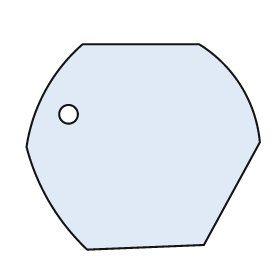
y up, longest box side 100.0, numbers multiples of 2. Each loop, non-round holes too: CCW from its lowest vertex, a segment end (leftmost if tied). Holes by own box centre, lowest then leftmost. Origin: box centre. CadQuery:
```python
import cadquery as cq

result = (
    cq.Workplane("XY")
    .moveTo(-24.0, -44.0)
    .lineTo(26.0, -42.0)
    .lineTo(50.0, 2.0)
    .threePointArc((42.0, 26.0), (24.0, 44.0))
    .lineTo(-26.0, 44.0)
    .threePointArc((-42.0, 24.0), (-50.0, 0.0))
    .threePointArc((-40.0, -24.0), (-24.0, -44.0))
    .close()
    .moveTo(-32.0, 14.0)
    .circle(4.0)
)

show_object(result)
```